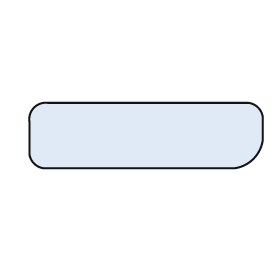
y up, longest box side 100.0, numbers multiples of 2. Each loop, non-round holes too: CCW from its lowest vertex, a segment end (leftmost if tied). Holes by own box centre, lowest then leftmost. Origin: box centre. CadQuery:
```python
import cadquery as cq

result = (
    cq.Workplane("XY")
    .moveTo(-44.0, -14.0)
    .lineTo(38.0, -14.0)
    .threePointArc((46.0, -10.0), (50.0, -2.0))
    .lineTo(50.0, 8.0)
    .threePointArc((48.0, 12.0), (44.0, 14.0))
    .lineTo(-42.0, 14.0)
    .threePointArc((-48.0, 12.0), (-50.0, 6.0))
    .lineTo(-50.0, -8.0)
    .threePointArc((-48.0, -12.0), (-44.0, -14.0))
    .close()
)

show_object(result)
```